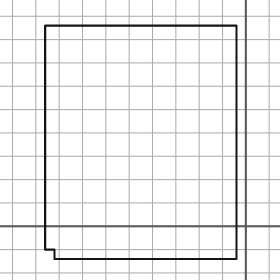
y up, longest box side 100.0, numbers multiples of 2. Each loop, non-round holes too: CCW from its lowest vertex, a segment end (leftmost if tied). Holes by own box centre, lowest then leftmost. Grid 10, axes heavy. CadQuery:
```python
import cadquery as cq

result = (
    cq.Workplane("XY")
    .moveTo(-82.0, -14.0)
    .lineTo(-4.0, -14.0)
    .lineTo(-4.0, 86.0)
    .lineTo(-86.0, 86.0)
    .lineTo(-86.0, -10.0)
    .lineTo(-82.0, -10.0)
    .close()
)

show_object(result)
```